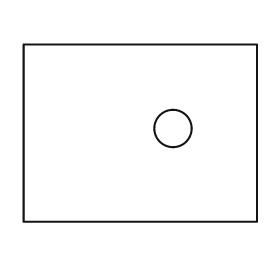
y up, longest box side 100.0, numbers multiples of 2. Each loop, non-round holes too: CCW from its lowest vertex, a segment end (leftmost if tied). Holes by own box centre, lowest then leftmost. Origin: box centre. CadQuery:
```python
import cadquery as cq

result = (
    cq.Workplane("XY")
    .moveTo(-50.0, -38.0)
    .lineTo(50.0, -38.0)
    .lineTo(50.0, 38.0)
    .lineTo(-50.0, 38.0)
    .close()
    .moveTo(14.0, 2.0)
    .circle(8.0)
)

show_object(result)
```